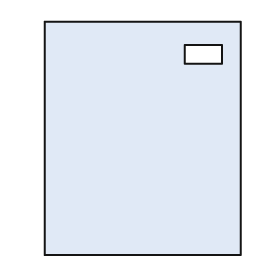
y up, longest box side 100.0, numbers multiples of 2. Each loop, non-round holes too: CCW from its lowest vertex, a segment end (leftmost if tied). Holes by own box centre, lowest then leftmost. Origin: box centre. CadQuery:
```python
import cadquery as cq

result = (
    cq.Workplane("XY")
    .moveTo(-42.0, -50.0)
    .lineTo(42.0, -50.0)
    .lineTo(42.0, 50.0)
    .lineTo(-42.0, 50.0)
    .close()
    .moveTo(18.0, 32.0)
    .lineTo(34.0, 32.0)
    .lineTo(34.0, 40.0)
    .lineTo(18.0, 40.0)
    .close()
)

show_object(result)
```